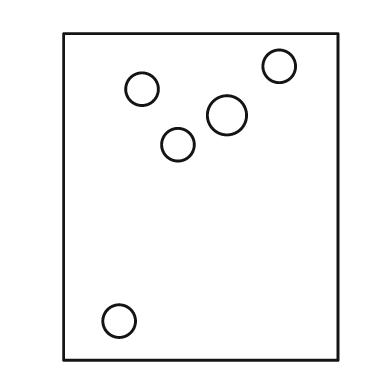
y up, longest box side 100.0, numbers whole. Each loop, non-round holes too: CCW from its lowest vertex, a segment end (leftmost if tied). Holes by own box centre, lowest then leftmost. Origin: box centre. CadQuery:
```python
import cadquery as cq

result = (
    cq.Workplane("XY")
    .moveTo(-42.0, -50.0)
    .lineTo(42.0, -50.0)
    .lineTo(42.0, 50.0)
    .lineTo(-42.0, 50.0)
    .close()
    .moveTo(-25.0, -38.0)
    .circle(5.0)
    .moveTo(-7.0, 16.0)
    .circle(5.0)
    .moveTo(8.0, 25.0)
    .circle(6.0)
    .moveTo(-18.0, 33.0)
    .circle(5.0)
    .moveTo(24.0, 40.0)
    .circle(5.0)
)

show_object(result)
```